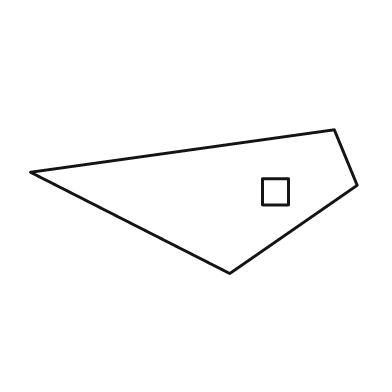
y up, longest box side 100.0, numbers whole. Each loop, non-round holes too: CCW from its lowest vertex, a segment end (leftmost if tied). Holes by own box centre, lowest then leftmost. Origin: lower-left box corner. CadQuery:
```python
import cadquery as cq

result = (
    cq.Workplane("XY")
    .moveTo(61.0, 0.0)
    .lineTo(100.0, 27.0)
    .lineTo(93.0, 44.0)
    .lineTo(0.0, 31.0)
    .close()
    .moveTo(71.0, 21.0)
    .lineTo(79.0, 21.0)
    .lineTo(79.0, 29.0)
    .lineTo(71.0, 29.0)
    .close()
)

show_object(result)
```